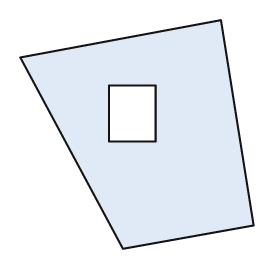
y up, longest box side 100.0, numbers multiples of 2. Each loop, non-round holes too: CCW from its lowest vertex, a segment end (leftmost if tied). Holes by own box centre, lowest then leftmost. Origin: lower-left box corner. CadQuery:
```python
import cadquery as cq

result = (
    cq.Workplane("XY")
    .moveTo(44.0, 0.0)
    .lineTo(100.0, 10.0)
    .lineTo(86.0, 98.0)
    .lineTo(0.0, 82.0)
    .close()
    .moveTo(38.0, 46.0)
    .lineTo(58.0, 46.0)
    .lineTo(58.0, 70.0)
    .lineTo(38.0, 70.0)
    .close()
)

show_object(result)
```